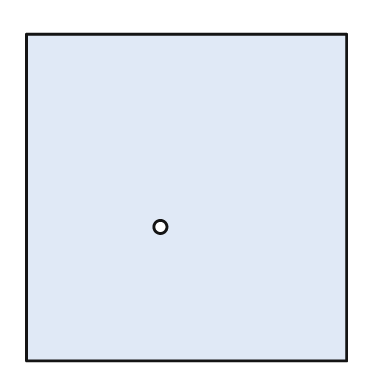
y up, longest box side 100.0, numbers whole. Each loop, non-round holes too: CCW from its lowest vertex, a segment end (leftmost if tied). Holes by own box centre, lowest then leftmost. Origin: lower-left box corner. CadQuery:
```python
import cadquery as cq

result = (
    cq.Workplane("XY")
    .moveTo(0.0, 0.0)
    .lineTo(98.0, 0.0)
    .lineTo(98.0, 100.0)
    .lineTo(0.0, 100.0)
    .close()
    .moveTo(41.0, 41.0)
    .circle(2.0)
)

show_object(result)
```